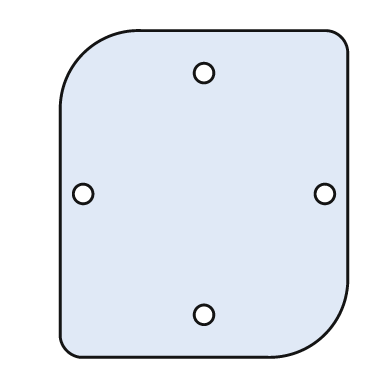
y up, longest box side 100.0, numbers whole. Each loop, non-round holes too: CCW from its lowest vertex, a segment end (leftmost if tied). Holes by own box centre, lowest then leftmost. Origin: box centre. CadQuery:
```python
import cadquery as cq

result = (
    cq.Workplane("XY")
    .moveTo(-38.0, -50.0)
    .lineTo(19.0, -50.0)
    .threePointArc((37.0, -43.0), (44.0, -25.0))
    .lineTo(44.0, 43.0)
    .threePointArc((42.0, 48.0), (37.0, 50.0))
    .lineTo(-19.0, 50.0)
    .threePointArc((-37.0, 43.0), (-44.0, 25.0))
    .lineTo(-44.0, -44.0)
    .threePointArc((-42.0, -48.0), (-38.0, -50.0))
    .close()
    .moveTo(0.0, -37.0)
    .circle(3.0)
    .moveTo(-37.0, 0.0)
    .circle(3.0)
    .moveTo(37.0, 0.0)
    .circle(3.0)
    .moveTo(0.0, 37.0)
    .circle(3.0)
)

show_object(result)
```